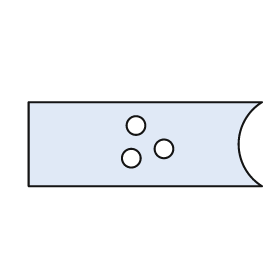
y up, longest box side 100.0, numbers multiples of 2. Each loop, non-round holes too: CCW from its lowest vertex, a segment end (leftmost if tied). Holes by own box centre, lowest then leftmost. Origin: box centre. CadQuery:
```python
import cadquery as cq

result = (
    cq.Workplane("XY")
    .moveTo(-50.0, -18.0)
    .lineTo(50.0, -18.0)
    .threePointArc((40.0, 0.0), (50.0, 18.0))
    .lineTo(-50.0, 18.0)
    .close()
    .moveTo(-6.0, -6.0)
    .circle(4.0)
    .moveTo(8.0, -2.0)
    .circle(4.0)
    .moveTo(-4.0, 8.0)
    .circle(4.0)
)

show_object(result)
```